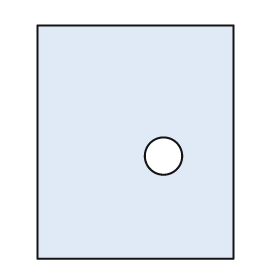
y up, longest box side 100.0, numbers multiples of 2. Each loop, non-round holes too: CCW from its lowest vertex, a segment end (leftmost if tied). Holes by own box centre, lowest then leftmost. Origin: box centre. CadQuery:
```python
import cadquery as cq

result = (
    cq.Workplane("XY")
    .moveTo(-42.0, -50.0)
    .lineTo(42.0, -50.0)
    .lineTo(42.0, 50.0)
    .lineTo(-42.0, 50.0)
    .close()
    .moveTo(12.0, -6.0)
    .circle(8.0)
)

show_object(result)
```